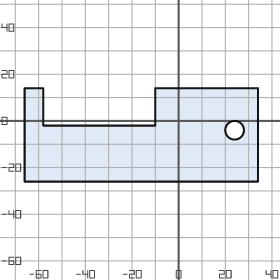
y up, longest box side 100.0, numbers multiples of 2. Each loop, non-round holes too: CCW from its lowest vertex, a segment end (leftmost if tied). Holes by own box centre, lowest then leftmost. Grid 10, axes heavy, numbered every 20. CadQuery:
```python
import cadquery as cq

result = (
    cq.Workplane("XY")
    .moveTo(-66.0, -26.0)
    .lineTo(34.0, -26.0)
    .lineTo(34.0, 14.0)
    .lineTo(-10.0, 14.0)
    .lineTo(-10.0, -2.0)
    .lineTo(-58.0, -2.0)
    .lineTo(-58.0, 14.0)
    .lineTo(-66.0, 14.0)
    .close()
    .moveTo(24.0, -4.0)
    .circle(4.0)
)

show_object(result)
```